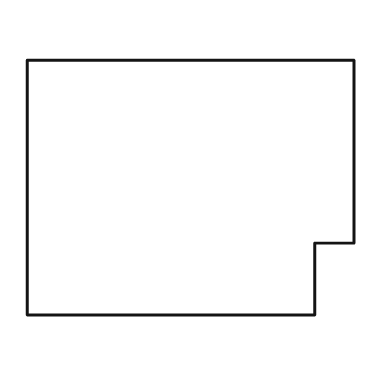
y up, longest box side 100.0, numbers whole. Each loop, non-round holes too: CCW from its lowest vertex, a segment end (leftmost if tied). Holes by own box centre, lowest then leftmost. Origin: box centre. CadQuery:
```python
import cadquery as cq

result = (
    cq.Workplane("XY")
    .moveTo(-50.0, -39.0)
    .lineTo(38.0, -39.0)
    .lineTo(38.0, -17.0)
    .lineTo(50.0, -17.0)
    .lineTo(50.0, 39.0)
    .lineTo(-50.0, 39.0)
    .close()
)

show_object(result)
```